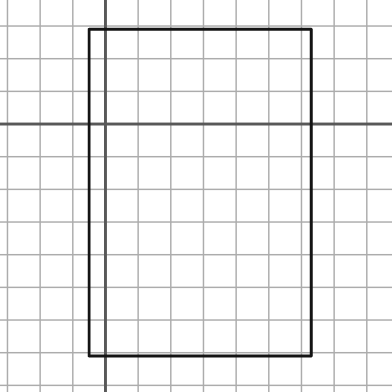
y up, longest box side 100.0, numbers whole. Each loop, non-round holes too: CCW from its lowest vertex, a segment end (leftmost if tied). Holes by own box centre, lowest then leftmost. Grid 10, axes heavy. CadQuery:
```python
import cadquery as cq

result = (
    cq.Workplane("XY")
    .moveTo(-5.0, -71.0)
    .lineTo(63.0, -71.0)
    .lineTo(63.0, 29.0)
    .lineTo(-5.0, 29.0)
    .close()
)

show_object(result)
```